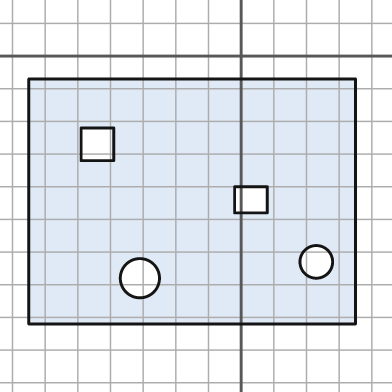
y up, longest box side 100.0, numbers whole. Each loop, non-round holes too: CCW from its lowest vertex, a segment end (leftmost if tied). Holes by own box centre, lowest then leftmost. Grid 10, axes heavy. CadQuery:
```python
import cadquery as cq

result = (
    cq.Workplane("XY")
    .moveTo(-65.0, -82.0)
    .lineTo(35.0, -82.0)
    .lineTo(35.0, -7.0)
    .lineTo(-65.0, -7.0)
    .close()
    .moveTo(-31.0, -68.0)
    .circle(6.0)
    .moveTo(23.0, -63.0)
    .circle(5.0)
    .moveTo(-2.0, -48.0)
    .lineTo(8.0, -48.0)
    .lineTo(8.0, -40.0)
    .lineTo(-2.0, -40.0)
    .close()
    .moveTo(-49.0, -32.0)
    .lineTo(-39.0, -32.0)
    .lineTo(-39.0, -22.0)
    .lineTo(-49.0, -22.0)
    .close()
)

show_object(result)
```